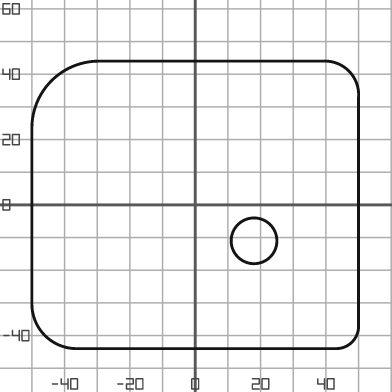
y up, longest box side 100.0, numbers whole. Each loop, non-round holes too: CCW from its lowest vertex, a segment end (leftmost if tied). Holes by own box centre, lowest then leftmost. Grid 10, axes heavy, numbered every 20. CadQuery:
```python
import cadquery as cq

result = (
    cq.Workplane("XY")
    .moveTo(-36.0, -44.0)
    .lineTo(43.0, -44.0)
    .threePointArc((48.0, -42.0), (50.0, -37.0))
    .lineTo(50.0, 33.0)
    .threePointArc((47.0, 41.0), (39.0, 44.0))
    .lineTo(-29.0, 44.0)
    .threePointArc((-44.0, 38.0), (-50.0, 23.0))
    .lineTo(-50.0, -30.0)
    .threePointArc((-46.0, -40.0), (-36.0, -44.0))
    .close()
    .moveTo(18.0, -11.0)
    .circle(7.0)
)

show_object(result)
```